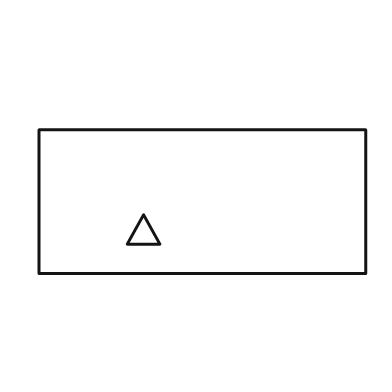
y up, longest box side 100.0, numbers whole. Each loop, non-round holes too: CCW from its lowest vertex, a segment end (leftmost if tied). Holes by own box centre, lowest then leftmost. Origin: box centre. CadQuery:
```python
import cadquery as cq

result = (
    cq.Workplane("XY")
    .moveTo(-50.0, -22.0)
    .lineTo(50.0, -22.0)
    .lineTo(50.0, 22.0)
    .lineTo(-50.0, 22.0)
    .close()
    .moveTo(-23.0, -13.0)
    .lineTo(-13.0, -13.0)
    .lineTo(-18.0, -4.0)
    .close()
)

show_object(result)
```